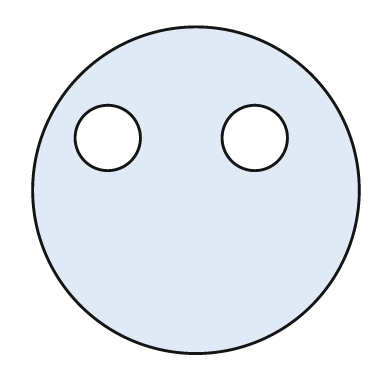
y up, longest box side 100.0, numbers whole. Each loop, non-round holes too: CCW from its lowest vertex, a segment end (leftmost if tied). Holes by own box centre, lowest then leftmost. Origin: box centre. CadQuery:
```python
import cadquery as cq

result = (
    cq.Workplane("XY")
    .moveTo(0.0, 0.0)
    .circle(50.0)
    .moveTo(-27.0, 16.0)
    .circle(10.0)
    .moveTo(18.0, 16.0)
    .circle(10.0)
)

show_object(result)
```